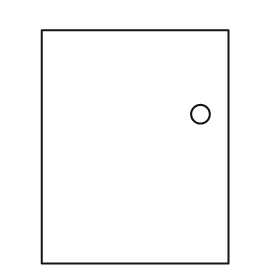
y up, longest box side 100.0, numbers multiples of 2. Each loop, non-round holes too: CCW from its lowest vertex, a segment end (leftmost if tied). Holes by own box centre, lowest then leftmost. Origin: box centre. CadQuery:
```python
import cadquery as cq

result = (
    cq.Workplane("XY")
    .moveTo(-40.0, -50.0)
    .lineTo(40.0, -50.0)
    .lineTo(40.0, 50.0)
    .lineTo(-40.0, 50.0)
    .close()
    .moveTo(28.0, 14.0)
    .circle(4.0)
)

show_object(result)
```